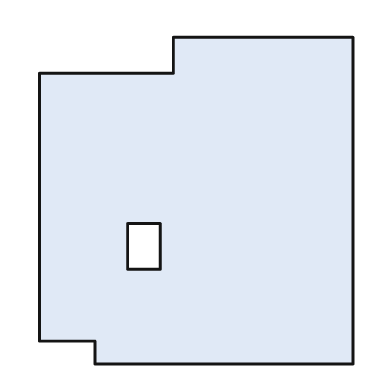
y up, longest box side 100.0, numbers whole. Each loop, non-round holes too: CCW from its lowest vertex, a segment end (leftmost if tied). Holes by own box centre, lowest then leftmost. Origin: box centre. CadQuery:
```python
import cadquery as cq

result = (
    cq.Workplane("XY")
    .moveTo(-31.0, -50.0)
    .lineTo(48.0, -50.0)
    .lineTo(48.0, 50.0)
    .lineTo(-7.0, 50.0)
    .lineTo(-7.0, 39.0)
    .lineTo(-48.0, 39.0)
    .lineTo(-48.0, -43.0)
    .lineTo(-31.0, -43.0)
    .close()
    .moveTo(-21.0, -21.0)
    .lineTo(-11.0, -21.0)
    .lineTo(-11.0, -7.0)
    .lineTo(-21.0, -7.0)
    .close()
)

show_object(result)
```